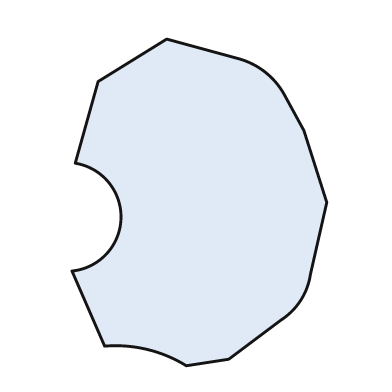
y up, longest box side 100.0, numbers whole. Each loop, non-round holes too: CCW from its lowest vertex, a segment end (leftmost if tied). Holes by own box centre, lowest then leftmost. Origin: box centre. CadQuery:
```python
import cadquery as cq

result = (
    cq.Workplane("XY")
    .moveTo(-4.0, -50.0)
    .lineTo(9.0, -48.0)
    .lineTo(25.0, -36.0)
    .threePointArc((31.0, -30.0), (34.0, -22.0))
    .lineTo(39.0, 0.0)
    .lineTo(32.0, 22.0)
    .lineTo(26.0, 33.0)
    .threePointArc((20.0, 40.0), (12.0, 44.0))
    .lineTo(-10.0, 50.0)
    .lineTo(-31.0, 37.0)
    .lineTo(-38.0, 12.0)
    .threePointArc((-24.0, -5.0), (-39.0, -21.0))
    .lineTo(-29.0, -44.0)
    .threePointArc((-16.0, -45.0), (-4.0, -50.0))
    .close()
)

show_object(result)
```